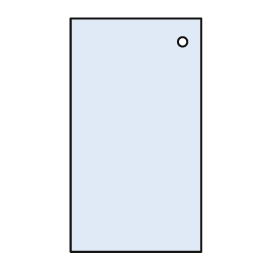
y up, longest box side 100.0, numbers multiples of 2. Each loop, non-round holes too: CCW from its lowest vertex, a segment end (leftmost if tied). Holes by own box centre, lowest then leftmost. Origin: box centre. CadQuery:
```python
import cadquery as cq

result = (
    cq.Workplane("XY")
    .moveTo(-28.0, -50.0)
    .lineTo(28.0, -50.0)
    .lineTo(28.0, 50.0)
    .lineTo(-28.0, 50.0)
    .close()
    .moveTo(20.0, 40.0)
    .circle(2.0)
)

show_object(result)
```